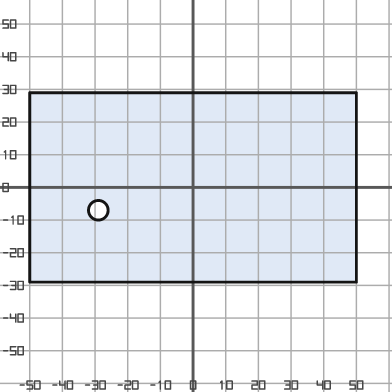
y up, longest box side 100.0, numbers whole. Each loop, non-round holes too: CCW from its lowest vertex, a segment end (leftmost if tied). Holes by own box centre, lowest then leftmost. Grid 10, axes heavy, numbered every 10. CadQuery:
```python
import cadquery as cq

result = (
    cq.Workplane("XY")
    .moveTo(-50.0, -29.0)
    .lineTo(50.0, -29.0)
    .lineTo(50.0, 29.0)
    .lineTo(-50.0, 29.0)
    .close()
    .moveTo(-29.0, -7.0)
    .circle(3.0)
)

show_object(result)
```